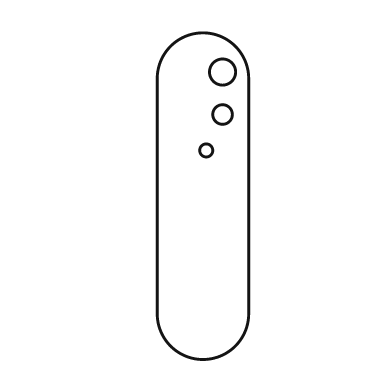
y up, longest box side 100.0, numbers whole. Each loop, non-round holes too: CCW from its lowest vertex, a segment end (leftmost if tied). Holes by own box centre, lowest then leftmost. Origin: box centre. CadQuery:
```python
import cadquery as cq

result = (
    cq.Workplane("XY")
    .moveTo(-14.0, -36.0)
    .threePointArc((0.0, -50.0), (14.0, -36.0))
    .lineTo(14.0, 36.0)
    .threePointArc((0.0, 50.0), (-14.0, 36.0))
    .close()
    .moveTo(1.0, 14.0)
    .circle(2.0)
    .moveTo(6.0, 25.0)
    .circle(3.0)
    .moveTo(6.0, 38.0)
    .circle(4.0)
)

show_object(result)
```